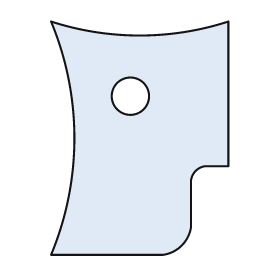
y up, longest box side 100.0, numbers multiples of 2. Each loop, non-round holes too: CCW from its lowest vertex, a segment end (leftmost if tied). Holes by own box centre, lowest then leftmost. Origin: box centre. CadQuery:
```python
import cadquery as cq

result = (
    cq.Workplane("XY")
    .moveTo(-38.0, -50.0)
    .lineTo(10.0, -50.0)
    .threePointArc((18.0, -46.0), (22.0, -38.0))
    .lineTo(22.0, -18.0)
    .threePointArc((24.0, -14.0), (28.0, -12.0))
    .lineTo(38.0, -12.0)
    .lineTo(38.0, 50.0)
    .threePointArc((0.0, 44.0), (-38.0, 50.0))
    .threePointArc((-28.0, 0.0), (-38.0, -50.0))
    .close()
    .moveTo(-4.0, 18.0)
    .circle(8.0)
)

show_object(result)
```